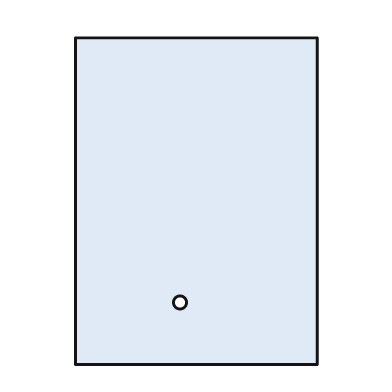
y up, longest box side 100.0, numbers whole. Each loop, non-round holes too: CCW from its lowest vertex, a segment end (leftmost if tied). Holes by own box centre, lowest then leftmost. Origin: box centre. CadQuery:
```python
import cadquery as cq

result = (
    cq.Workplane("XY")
    .moveTo(-37.0, -50.0)
    .lineTo(37.0, -50.0)
    .lineTo(37.0, 50.0)
    .lineTo(-37.0, 50.0)
    .close()
    .moveTo(-5.0, -31.0)
    .circle(2.0)
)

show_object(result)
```